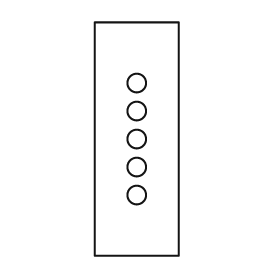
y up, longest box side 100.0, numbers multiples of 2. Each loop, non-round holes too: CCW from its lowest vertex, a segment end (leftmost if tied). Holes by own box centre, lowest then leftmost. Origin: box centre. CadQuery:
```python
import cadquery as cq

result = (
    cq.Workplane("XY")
    .moveTo(-18.0, -50.0)
    .lineTo(18.0, -50.0)
    .lineTo(18.0, 50.0)
    .lineTo(-18.0, 50.0)
    .close()
    .moveTo(0.0, -24.0)
    .circle(4.0)
    .moveTo(0.0, -12.0)
    .circle(4.0)
    .moveTo(0.0, 0.0)
    .circle(4.0)
    .moveTo(0.0, 12.0)
    .circle(4.0)
    .moveTo(0.0, 24.0)
    .circle(4.0)
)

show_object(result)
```